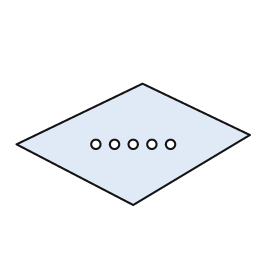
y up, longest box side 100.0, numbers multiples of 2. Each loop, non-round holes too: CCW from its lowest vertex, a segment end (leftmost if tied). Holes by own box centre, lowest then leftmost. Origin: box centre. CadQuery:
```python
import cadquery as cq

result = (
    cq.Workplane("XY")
    .moveTo(0.0, -26.0)
    .lineTo(50.0, 4.0)
    .lineTo(4.0, 26.0)
    .lineTo(-50.0, 0.0)
    .close()
    .moveTo(-16.0, 0.0)
    .circle(2.0)
    .moveTo(-8.0, 0.0)
    .circle(2.0)
    .moveTo(0.0, 0.0)
    .circle(2.0)
    .moveTo(8.0, 0.0)
    .circle(2.0)
    .moveTo(16.0, 0.0)
    .circle(2.0)
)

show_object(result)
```